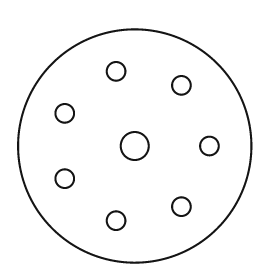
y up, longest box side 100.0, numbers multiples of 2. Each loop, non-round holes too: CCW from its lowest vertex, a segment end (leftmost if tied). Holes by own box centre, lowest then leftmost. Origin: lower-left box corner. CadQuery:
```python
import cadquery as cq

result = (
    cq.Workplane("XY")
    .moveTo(50.0, 50.0)
    .circle(50.0)
    .moveTo(42.0, 18.0)
    .circle(4.0)
    .moveTo(70.0, 24.0)
    .circle(4.0)
    .moveTo(20.0, 36.0)
    .circle(4.0)
    .moveTo(50.0, 50.0)
    .circle(6.0)
    .moveTo(82.0, 50.0)
    .circle(4.0)
    .moveTo(20.0, 64.0)
    .circle(4.0)
    .moveTo(70.0, 76.0)
    .circle(4.0)
    .moveTo(42.0, 82.0)
    .circle(4.0)
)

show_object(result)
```